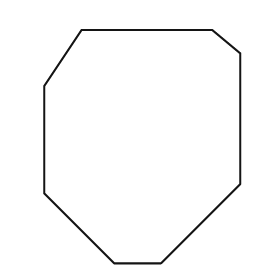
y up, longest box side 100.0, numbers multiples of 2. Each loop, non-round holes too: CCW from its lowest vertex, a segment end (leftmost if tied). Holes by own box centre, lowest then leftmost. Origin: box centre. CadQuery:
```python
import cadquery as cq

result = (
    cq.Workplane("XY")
    .moveTo(-12.0, -50.0)
    .lineTo(8.0, -50.0)
    .lineTo(42.0, -16.0)
    .lineTo(42.0, 40.0)
    .lineTo(30.0, 50.0)
    .lineTo(-26.0, 50.0)
    .lineTo(-42.0, 26.0)
    .lineTo(-42.0, -20.0)
    .close()
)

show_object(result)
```